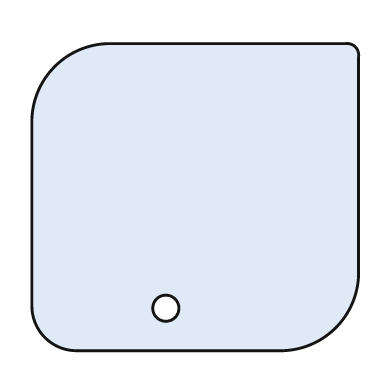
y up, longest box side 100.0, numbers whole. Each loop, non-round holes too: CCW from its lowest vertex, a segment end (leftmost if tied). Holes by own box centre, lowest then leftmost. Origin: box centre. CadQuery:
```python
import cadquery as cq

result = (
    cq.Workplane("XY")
    .moveTo(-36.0, -47.0)
    .lineTo(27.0, -47.0)
    .threePointArc((43.0, -40.0), (50.0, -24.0))
    .lineTo(50.0, 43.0)
    .threePointArc((49.0, 46.0), (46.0, 47.0))
    .lineTo(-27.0, 47.0)
    .threePointArc((-43.0, 40.0), (-50.0, 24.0))
    .lineTo(-50.0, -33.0)
    .threePointArc((-46.0, -43.0), (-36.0, -47.0))
    .close()
    .moveTo(-9.0, -34.0)
    .circle(4.0)
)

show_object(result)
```